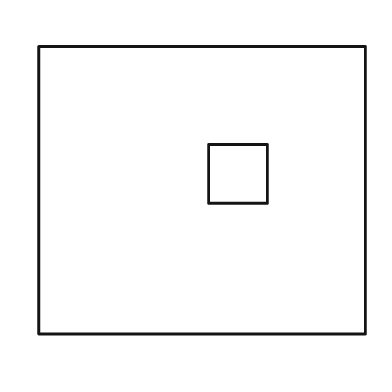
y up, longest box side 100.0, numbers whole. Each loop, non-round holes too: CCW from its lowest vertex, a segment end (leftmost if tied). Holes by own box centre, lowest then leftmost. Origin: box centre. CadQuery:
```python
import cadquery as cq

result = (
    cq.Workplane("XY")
    .moveTo(-50.0, -44.0)
    .lineTo(50.0, -44.0)
    .lineTo(50.0, 44.0)
    .lineTo(-50.0, 44.0)
    .close()
    .moveTo(2.0, -4.0)
    .lineTo(20.0, -4.0)
    .lineTo(20.0, 14.0)
    .lineTo(2.0, 14.0)
    .close()
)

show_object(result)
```